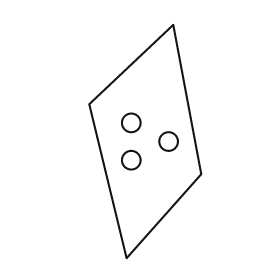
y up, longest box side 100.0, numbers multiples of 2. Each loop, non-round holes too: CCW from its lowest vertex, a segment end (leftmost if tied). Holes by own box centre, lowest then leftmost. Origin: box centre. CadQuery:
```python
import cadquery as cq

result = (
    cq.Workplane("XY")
    .moveTo(-8.0, -50.0)
    .lineTo(24.0, -14.0)
    .lineTo(12.0, 50.0)
    .lineTo(-24.0, 16.0)
    .close()
    .moveTo(-6.0, -8.0)
    .circle(4.0)
    .moveTo(10.0, 0.0)
    .circle(4.0)
    .moveTo(-6.0, 8.0)
    .circle(4.0)
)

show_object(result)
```